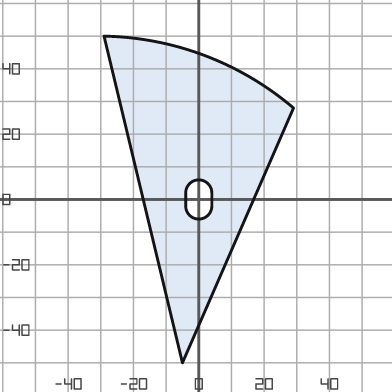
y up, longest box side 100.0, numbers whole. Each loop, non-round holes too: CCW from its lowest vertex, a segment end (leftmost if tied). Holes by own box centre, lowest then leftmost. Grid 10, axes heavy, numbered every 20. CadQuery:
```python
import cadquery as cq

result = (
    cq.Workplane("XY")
    .moveTo(-5.0, -50.0)
    .lineTo(29.0, 28.0)
    .threePointArc((2.0, 44.0), (-29.0, 50.0))
    .close()
    .moveTo(-4.0, -2.0)
    .threePointArc((0.0, -6.0), (4.0, -2.0))
    .lineTo(4.0, 2.0)
    .threePointArc((0.0, 6.0), (-4.0, 2.0))
    .close()
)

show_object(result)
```